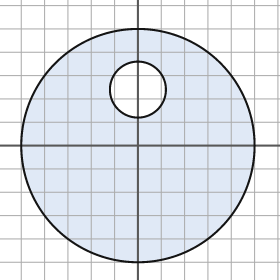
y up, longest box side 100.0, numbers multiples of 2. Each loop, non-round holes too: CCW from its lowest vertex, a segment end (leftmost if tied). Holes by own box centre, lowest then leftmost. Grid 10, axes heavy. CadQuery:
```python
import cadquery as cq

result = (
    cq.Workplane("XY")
    .moveTo(0.0, 0.0)
    .circle(50.0)
    .moveTo(0.0, 24.0)
    .circle(12.0)
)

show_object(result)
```